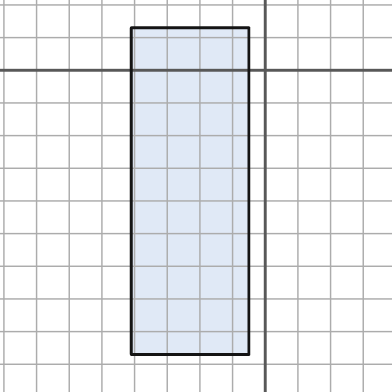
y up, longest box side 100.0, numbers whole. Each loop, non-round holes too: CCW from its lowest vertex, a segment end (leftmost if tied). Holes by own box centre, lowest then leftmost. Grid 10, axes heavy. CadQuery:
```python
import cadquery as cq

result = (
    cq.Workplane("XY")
    .moveTo(-41.0, -87.0)
    .lineTo(-5.0, -87.0)
    .lineTo(-5.0, 13.0)
    .lineTo(-41.0, 13.0)
    .close()
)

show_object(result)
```